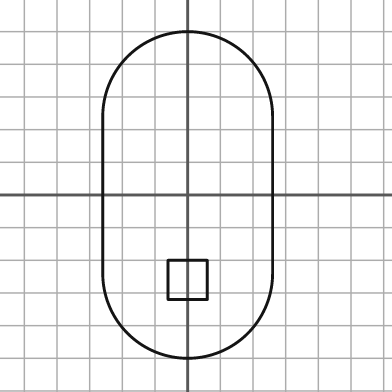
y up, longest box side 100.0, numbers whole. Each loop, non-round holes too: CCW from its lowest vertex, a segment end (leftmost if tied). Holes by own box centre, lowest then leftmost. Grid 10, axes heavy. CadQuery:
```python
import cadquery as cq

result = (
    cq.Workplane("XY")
    .moveTo(-26.0, -24.0)
    .threePointArc((0.0, -50.0), (26.0, -24.0))
    .lineTo(26.0, 24.0)
    .threePointArc((0.0, 50.0), (-26.0, 24.0))
    .close()
    .moveTo(-6.0, -32.0)
    .lineTo(6.0, -32.0)
    .lineTo(6.0, -20.0)
    .lineTo(-6.0, -20.0)
    .close()
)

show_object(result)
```